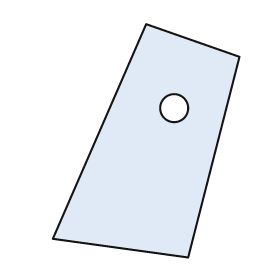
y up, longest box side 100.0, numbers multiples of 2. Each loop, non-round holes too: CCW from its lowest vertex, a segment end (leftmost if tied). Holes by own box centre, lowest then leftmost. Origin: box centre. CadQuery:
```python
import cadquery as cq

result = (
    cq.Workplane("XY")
    .moveTo(18.0, -50.0)
    .lineTo(40.0, 36.0)
    .lineTo(0.0, 50.0)
    .lineTo(-40.0, -42.0)
    .close()
    .moveTo(12.0, 14.0)
    .circle(6.0)
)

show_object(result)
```